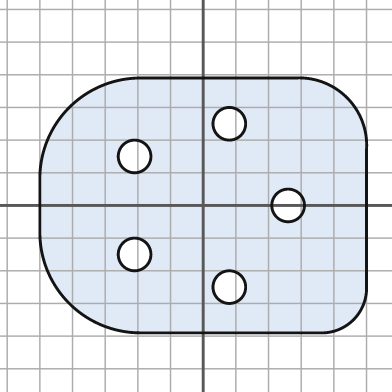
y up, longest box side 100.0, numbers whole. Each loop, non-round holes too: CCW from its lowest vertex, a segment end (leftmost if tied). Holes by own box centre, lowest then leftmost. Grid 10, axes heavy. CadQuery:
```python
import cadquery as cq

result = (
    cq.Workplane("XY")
    .moveTo(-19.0, -39.0)
    .lineTo(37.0, -39.0)
    .threePointArc((46.0, -35.0), (50.0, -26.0))
    .lineTo(50.0, 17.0)
    .threePointArc((44.0, 33.0), (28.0, 39.0))
    .lineTo(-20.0, 39.0)
    .threePointArc((-41.0, 30.0), (-50.0, 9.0))
    .lineTo(-50.0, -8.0)
    .threePointArc((-41.0, -30.0), (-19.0, -39.0))
    .close()
    .moveTo(8.0, -25.0)
    .circle(5.0)
    .moveTo(-21.0, -15.0)
    .circle(5.0)
    .moveTo(26.0, 0.0)
    .circle(5.0)
    .moveTo(-21.0, 15.0)
    .circle(5.0)
    .moveTo(8.0, 25.0)
    .circle(5.0)
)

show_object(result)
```